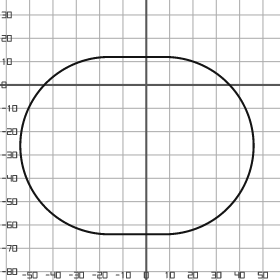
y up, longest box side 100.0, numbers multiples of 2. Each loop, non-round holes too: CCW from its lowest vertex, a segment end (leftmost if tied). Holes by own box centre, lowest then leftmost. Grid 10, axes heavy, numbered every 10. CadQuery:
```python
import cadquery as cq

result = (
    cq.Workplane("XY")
    .moveTo(-16.0, -64.0)
    .lineTo(8.0, -64.0)
    .threePointArc((46.0, -26.0), (8.0, 12.0))
    .lineTo(-16.0, 12.0)
    .threePointArc((-54.0, -26.0), (-16.0, -64.0))
    .close()
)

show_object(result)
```